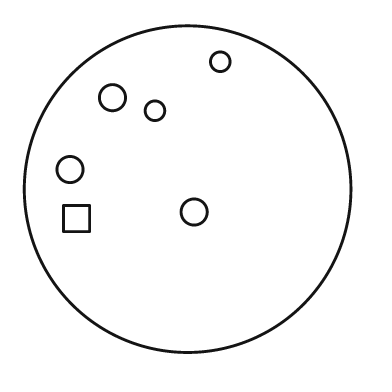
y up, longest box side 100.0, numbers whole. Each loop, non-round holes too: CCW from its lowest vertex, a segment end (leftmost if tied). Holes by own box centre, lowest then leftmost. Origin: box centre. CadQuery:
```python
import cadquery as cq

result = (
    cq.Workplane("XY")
    .moveTo(0.0, 0.0)
    .circle(50.0)
    .moveTo(-38.0, -13.0)
    .lineTo(-30.0, -13.0)
    .lineTo(-30.0, -5.0)
    .lineTo(-38.0, -5.0)
    .close()
    .moveTo(2.0, -7.0)
    .circle(4.0)
    .moveTo(-36.0, 6.0)
    .circle(4.0)
    .moveTo(-10.0, 24.0)
    .circle(3.0)
    .moveTo(-23.0, 28.0)
    .circle(4.0)
    .moveTo(10.0, 39.0)
    .circle(3.0)
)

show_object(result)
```